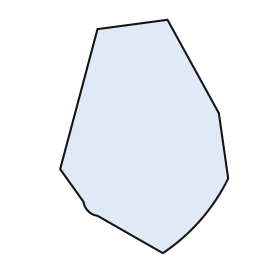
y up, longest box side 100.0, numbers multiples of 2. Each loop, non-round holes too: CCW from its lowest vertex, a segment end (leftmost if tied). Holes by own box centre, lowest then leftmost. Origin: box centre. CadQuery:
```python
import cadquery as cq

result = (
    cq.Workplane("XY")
    .moveTo(8.0, -50.0)
    .threePointArc((24.0, -36.0), (36.0, -18.0))
    .lineTo(32.0, 10.0)
    .lineTo(10.0, 50.0)
    .lineTo(-20.0, 46.0)
    .lineTo(-36.0, -14.0)
    .lineTo(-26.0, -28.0)
    .threePointArc((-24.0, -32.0), (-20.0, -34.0))
    .close()
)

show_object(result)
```